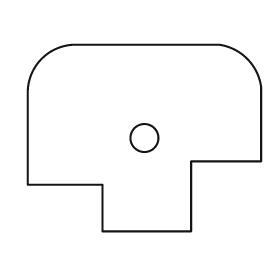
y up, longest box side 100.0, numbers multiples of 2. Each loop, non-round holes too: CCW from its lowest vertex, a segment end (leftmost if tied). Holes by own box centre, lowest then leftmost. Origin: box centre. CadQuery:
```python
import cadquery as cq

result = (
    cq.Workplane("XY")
    .moveTo(-18.0, -40.0)
    .lineTo(20.0, -40.0)
    .lineTo(20.0, -10.0)
    .lineTo(50.0, -10.0)
    .lineTo(50.0, 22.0)
    .threePointArc((44.0, 34.0), (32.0, 40.0))
    .lineTo(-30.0, 40.0)
    .threePointArc((-44.0, 34.0), (-50.0, 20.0))
    .lineTo(-50.0, -20.0)
    .lineTo(-18.0, -20.0)
    .close()
    .moveTo(0.0, 0.0)
    .circle(6.0)
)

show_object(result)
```